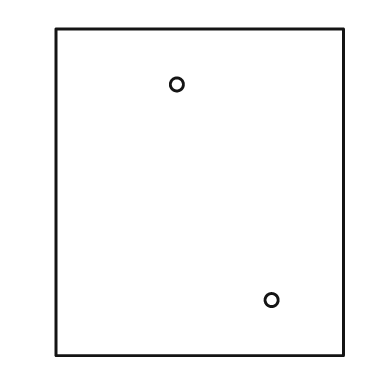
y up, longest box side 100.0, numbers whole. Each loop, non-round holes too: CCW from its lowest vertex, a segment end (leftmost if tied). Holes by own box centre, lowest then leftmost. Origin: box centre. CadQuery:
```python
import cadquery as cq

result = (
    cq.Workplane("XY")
    .moveTo(-44.0, -50.0)
    .lineTo(44.0, -50.0)
    .lineTo(44.0, 50.0)
    .lineTo(-44.0, 50.0)
    .close()
    .moveTo(22.0, -33.0)
    .circle(2.0)
    .moveTo(-7.0, 33.0)
    .circle(2.0)
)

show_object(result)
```